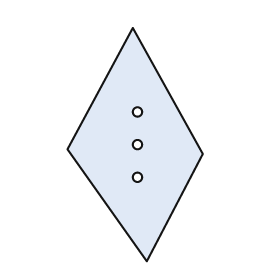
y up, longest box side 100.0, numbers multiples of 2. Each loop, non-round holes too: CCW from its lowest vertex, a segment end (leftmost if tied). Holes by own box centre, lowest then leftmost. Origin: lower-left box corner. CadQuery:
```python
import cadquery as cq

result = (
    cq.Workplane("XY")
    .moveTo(34.0, 0.0)
    .lineTo(58.0, 46.0)
    .lineTo(28.0, 100.0)
    .lineTo(0.0, 48.0)
    .close()
    .moveTo(30.0, 36.0)
    .circle(2.0)
    .moveTo(30.0, 50.0)
    .circle(2.0)
    .moveTo(30.0, 64.0)
    .circle(2.0)
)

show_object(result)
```